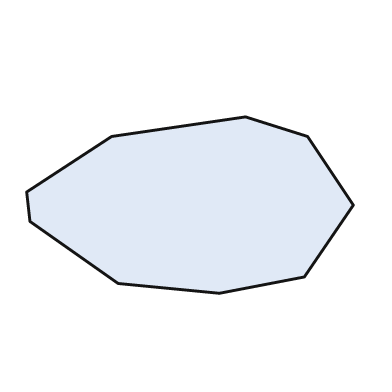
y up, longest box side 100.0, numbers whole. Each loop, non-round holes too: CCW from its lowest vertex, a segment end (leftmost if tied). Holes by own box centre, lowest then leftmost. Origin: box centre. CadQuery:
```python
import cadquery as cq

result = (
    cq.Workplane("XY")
    .moveTo(9.0, -27.0)
    .lineTo(35.0, -22.0)
    .lineTo(50.0, 0.0)
    .lineTo(36.0, 21.0)
    .lineTo(17.0, 27.0)
    .lineTo(-24.0, 21.0)
    .lineTo(-50.0, 4.0)
    .lineTo(-49.0, -5.0)
    .lineTo(-22.0, -24.0)
    .close()
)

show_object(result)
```